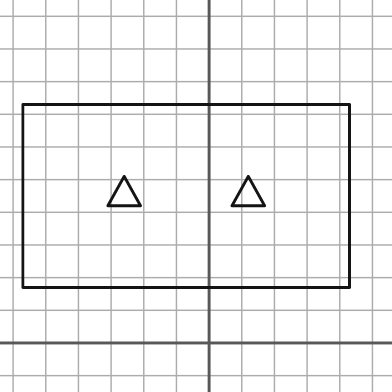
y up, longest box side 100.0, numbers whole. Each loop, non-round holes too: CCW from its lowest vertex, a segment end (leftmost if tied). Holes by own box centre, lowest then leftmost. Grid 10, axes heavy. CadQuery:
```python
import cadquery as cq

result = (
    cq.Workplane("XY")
    .moveTo(-57.0, 17.0)
    .lineTo(43.0, 17.0)
    .lineTo(43.0, 73.0)
    .lineTo(-57.0, 73.0)
    .close()
    .moveTo(-31.0, 42.0)
    .lineTo(-21.0, 42.0)
    .lineTo(-26.0, 51.0)
    .close()
    .moveTo(7.0, 42.0)
    .lineTo(17.0, 42.0)
    .lineTo(12.0, 51.0)
    .close()
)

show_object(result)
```